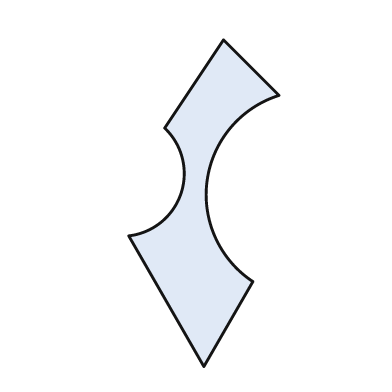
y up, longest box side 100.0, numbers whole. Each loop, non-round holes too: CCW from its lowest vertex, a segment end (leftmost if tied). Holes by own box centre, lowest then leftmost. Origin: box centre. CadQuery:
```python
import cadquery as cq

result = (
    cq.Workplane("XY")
    .moveTo(0.0, -50.0)
    .lineTo(15.0, -24.0)
    .threePointArc((1.0, 7.0), (23.0, 33.0))
    .lineTo(6.0, 50.0)
    .lineTo(-12.0, 23.0)
    .threePointArc((-7.0, 3.0), (-23.0, -10.0))
    .close()
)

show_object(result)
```